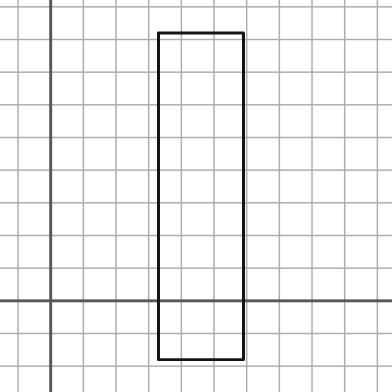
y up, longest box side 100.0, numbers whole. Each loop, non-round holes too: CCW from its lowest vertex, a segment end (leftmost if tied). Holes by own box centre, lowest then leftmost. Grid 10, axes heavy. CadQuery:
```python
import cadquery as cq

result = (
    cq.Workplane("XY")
    .moveTo(33.0, -18.0)
    .lineTo(59.0, -18.0)
    .lineTo(59.0, 82.0)
    .lineTo(33.0, 82.0)
    .close()
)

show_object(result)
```